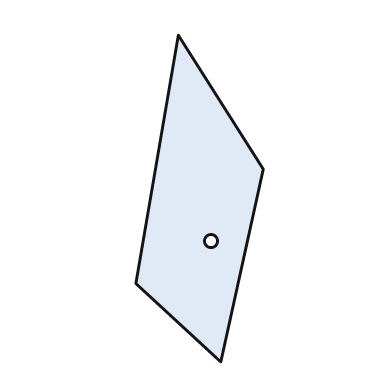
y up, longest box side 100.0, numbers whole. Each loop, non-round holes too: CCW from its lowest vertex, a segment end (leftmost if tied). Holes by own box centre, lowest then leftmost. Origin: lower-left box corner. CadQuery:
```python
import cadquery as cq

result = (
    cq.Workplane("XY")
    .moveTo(26.0, 0.0)
    .lineTo(39.0, 59.0)
    .lineTo(13.0, 100.0)
    .lineTo(0.0, 24.0)
    .close()
    .moveTo(23.0, 37.0)
    .circle(2.0)
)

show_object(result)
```